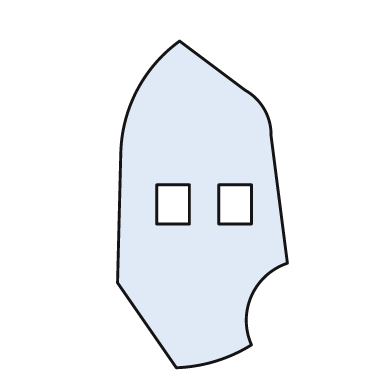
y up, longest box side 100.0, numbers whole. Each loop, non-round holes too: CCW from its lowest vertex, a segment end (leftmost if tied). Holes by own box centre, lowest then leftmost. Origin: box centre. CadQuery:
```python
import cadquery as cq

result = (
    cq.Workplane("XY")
    .moveTo(-8.0, -50.0)
    .threePointArc((4.0, -48.0), (15.0, -43.0))
    .threePointArc((15.0, -28.0), (26.0, -18.0))
    .lineTo(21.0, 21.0)
    .threePointArc((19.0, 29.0), (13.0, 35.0))
    .lineTo(-7.0, 50.0)
    .threePointArc((-20.0, 35.0), (-25.0, 16.0))
    .lineTo(-26.0, -24.0)
    .close()
    .moveTo(-14.0, -6.0)
    .lineTo(-4.0, -6.0)
    .lineTo(-4.0, 6.0)
    .lineTo(-14.0, 6.0)
    .close()
    .moveTo(5.0, -6.0)
    .lineTo(15.0, -6.0)
    .lineTo(15.0, 6.0)
    .lineTo(5.0, 6.0)
    .close()
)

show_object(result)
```